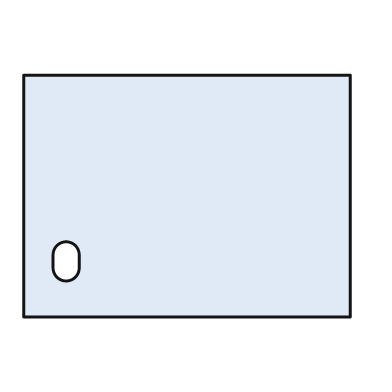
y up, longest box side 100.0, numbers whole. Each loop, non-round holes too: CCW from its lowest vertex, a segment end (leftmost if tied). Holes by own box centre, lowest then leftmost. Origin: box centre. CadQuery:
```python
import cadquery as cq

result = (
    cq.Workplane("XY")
    .moveTo(-50.0, -37.0)
    .lineTo(50.0, -37.0)
    .lineTo(50.0, 37.0)
    .lineTo(-50.0, 37.0)
    .close()
    .moveTo(-41.0, -22.0)
    .threePointArc((-37.0, -26.0), (-33.0, -22.0))
    .lineTo(-33.0, -18.0)
    .threePointArc((-37.0, -14.0), (-41.0, -18.0))
    .close()
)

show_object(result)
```